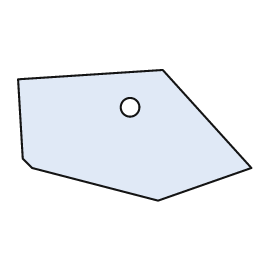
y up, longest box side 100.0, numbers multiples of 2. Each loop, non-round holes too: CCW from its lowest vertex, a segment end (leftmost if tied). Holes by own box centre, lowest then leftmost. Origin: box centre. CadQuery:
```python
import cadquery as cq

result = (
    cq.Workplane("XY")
    .moveTo(10.0, -28.0)
    .lineTo(50.0, -14.0)
    .lineTo(12.0, 28.0)
    .lineTo(-50.0, 24.0)
    .lineTo(-48.0, -10.0)
    .lineTo(-44.0, -14.0)
    .close()
    .moveTo(-2.0, 12.0)
    .circle(4.0)
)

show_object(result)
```